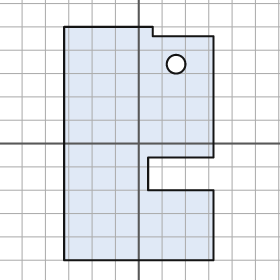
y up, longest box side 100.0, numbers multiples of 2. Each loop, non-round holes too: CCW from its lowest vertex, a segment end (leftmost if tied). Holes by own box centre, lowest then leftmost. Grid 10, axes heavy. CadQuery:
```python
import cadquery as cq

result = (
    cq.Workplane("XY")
    .moveTo(-32.0, -50.0)
    .lineTo(32.0, -50.0)
    .lineTo(32.0, -20.0)
    .lineTo(4.0, -20.0)
    .lineTo(4.0, -6.0)
    .lineTo(32.0, -6.0)
    .lineTo(32.0, 46.0)
    .lineTo(6.0, 46.0)
    .lineTo(6.0, 50.0)
    .lineTo(-32.0, 50.0)
    .close()
    .moveTo(16.0, 34.0)
    .circle(4.0)
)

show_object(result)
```